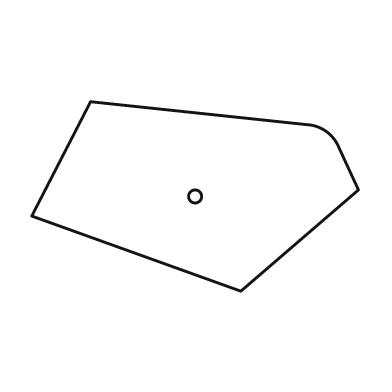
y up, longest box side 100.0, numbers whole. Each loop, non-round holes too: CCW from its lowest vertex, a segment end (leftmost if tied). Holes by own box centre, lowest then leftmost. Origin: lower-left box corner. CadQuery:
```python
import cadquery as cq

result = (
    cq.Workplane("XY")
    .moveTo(64.0, 0.0)
    .lineTo(100.0, 31.0)
    .lineTo(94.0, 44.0)
    .threePointArc((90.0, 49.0), (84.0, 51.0))
    .lineTo(18.0, 58.0)
    .lineTo(0.0, 23.0)
    .close()
    .moveTo(50.0, 29.0)
    .circle(2.0)
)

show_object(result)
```